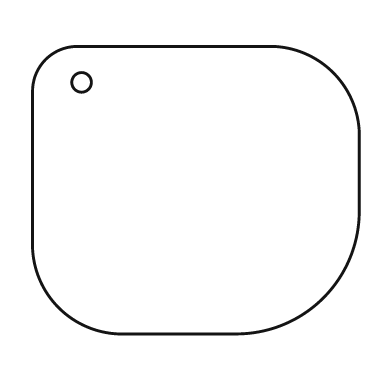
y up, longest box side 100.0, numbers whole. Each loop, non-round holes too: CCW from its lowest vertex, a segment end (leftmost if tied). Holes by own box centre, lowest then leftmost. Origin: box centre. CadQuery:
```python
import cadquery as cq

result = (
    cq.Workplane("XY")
    .moveTo(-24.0, -44.0)
    .lineTo(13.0, -44.0)
    .threePointArc((39.0, -33.0), (50.0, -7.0))
    .lineTo(50.0, 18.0)
    .threePointArc((42.0, 36.0), (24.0, 44.0))
    .lineTo(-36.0, 44.0)
    .threePointArc((-46.0, 40.0), (-50.0, 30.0))
    .lineTo(-50.0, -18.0)
    .threePointArc((-42.0, -36.0), (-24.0, -44.0))
    .close()
    .moveTo(-35.0, 33.0)
    .circle(3.0)
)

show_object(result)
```